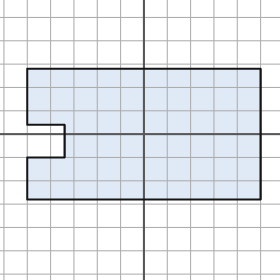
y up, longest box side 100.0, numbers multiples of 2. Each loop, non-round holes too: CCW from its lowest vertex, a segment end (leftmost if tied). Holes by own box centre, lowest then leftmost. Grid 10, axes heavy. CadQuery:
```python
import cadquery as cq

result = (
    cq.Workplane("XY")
    .moveTo(-50.0, -28.0)
    .lineTo(50.0, -28.0)
    .lineTo(50.0, 28.0)
    .lineTo(-50.0, 28.0)
    .lineTo(-50.0, 4.0)
    .lineTo(-34.0, 4.0)
    .lineTo(-34.0, -10.0)
    .lineTo(-50.0, -10.0)
    .close()
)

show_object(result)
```